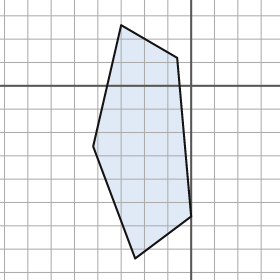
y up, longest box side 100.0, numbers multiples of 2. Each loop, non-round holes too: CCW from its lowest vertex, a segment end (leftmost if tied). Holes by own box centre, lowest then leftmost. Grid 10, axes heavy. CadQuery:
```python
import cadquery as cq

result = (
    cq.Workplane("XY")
    .moveTo(-24.0, -74.0)
    .lineTo(0.0, -56.0)
    .lineTo(-6.0, 12.0)
    .lineTo(-30.0, 26.0)
    .lineTo(-42.0, -26.0)
    .close()
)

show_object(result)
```